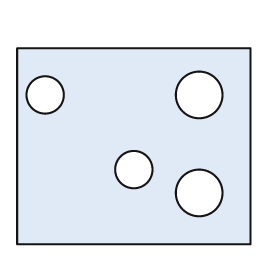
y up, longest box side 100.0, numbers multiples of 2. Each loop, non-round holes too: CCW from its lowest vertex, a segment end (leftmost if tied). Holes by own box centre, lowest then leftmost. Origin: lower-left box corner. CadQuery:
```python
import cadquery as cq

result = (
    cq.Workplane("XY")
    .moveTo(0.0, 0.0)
    .lineTo(100.0, 0.0)
    .lineTo(100.0, 84.0)
    .lineTo(0.0, 84.0)
    .close()
    .moveTo(78.0, 22.0)
    .circle(10.0)
    .moveTo(50.0, 32.0)
    .circle(8.0)
    .moveTo(12.0, 64.0)
    .circle(8.0)
    .moveTo(78.0, 64.0)
    .circle(10.0)
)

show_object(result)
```